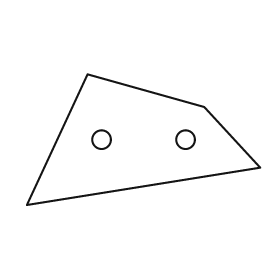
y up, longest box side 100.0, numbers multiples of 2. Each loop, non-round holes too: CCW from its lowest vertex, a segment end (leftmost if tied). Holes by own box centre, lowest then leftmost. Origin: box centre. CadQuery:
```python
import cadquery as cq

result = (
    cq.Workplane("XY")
    .moveTo(-50.0, -28.0)
    .lineTo(50.0, -12.0)
    .lineTo(26.0, 14.0)
    .lineTo(-24.0, 28.0)
    .close()
    .moveTo(-18.0, 0.0)
    .circle(4.0)
    .moveTo(18.0, 0.0)
    .circle(4.0)
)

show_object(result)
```